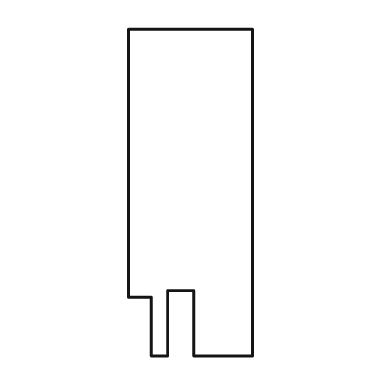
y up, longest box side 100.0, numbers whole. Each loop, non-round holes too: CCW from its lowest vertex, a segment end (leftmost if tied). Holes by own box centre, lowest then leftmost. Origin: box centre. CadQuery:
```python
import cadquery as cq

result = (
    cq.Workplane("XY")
    .moveTo(-12.0, -50.0)
    .lineTo(-7.0, -50.0)
    .lineTo(-7.0, -30.0)
    .lineTo(1.0, -30.0)
    .lineTo(1.0, -50.0)
    .lineTo(19.0, -50.0)
    .lineTo(19.0, 50.0)
    .lineTo(-19.0, 50.0)
    .lineTo(-19.0, -32.0)
    .lineTo(-12.0, -32.0)
    .close()
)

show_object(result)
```